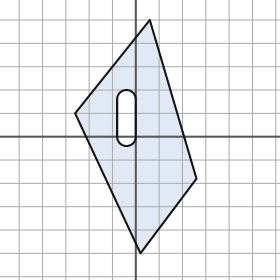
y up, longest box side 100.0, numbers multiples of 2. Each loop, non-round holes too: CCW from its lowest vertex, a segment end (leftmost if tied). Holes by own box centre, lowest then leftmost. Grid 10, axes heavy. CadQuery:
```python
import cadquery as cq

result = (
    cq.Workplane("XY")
    .moveTo(2.0, -50.0)
    .lineTo(26.0, -18.0)
    .lineTo(6.0, 50.0)
    .lineTo(-26.0, 10.0)
    .close()
    .moveTo(-8.0, 0.0)
    .threePointArc((-4.0, -4.0), (0.0, 0.0))
    .lineTo(0.0, 16.0)
    .threePointArc((-4.0, 20.0), (-8.0, 16.0))
    .close()
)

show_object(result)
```